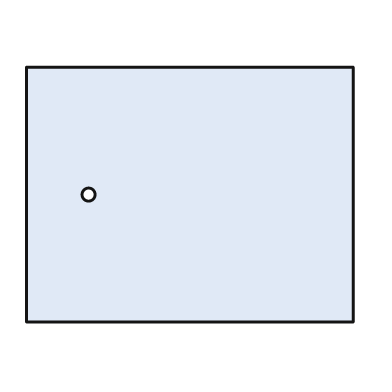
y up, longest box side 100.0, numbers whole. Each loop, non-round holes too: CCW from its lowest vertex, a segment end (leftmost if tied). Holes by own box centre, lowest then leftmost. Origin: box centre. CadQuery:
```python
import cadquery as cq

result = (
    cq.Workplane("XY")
    .moveTo(-50.0, -39.0)
    .lineTo(50.0, -39.0)
    .lineTo(50.0, 39.0)
    .lineTo(-50.0, 39.0)
    .close()
    .moveTo(-31.0, 0.0)
    .circle(2.0)
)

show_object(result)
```